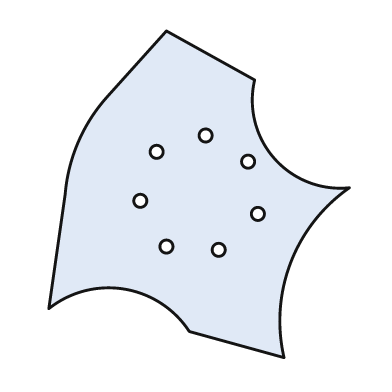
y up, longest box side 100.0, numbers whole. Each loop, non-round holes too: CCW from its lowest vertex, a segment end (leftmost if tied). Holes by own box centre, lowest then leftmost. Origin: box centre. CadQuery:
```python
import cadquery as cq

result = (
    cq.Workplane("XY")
    .moveTo(26.0, -50.0)
    .threePointArc((28.0, -21.0), (46.0, 2.0))
    .threePointArc((23.0, 11.0), (17.0, 35.0))
    .lineTo(-10.0, 50.0)
    .lineTo(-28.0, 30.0)
    .threePointArc((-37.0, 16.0), (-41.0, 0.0))
    .lineTo(-46.0, -35.0)
    .threePointArc((-23.0, -29.0), (-3.0, -42.0))
    .close()
    .moveTo(6.0, -17.0)
    .circle(2.0)
    .moveTo(-10.0, -16.0)
    .circle(2.0)
    .moveTo(18.0, -6.0)
    .circle(2.0)
    .moveTo(-18.0, -2.0)
    .circle(2.0)
    .moveTo(15.0, 10.0)
    .circle(2.0)
    .moveTo(-13.0, 13.0)
    .circle(2.0)
    .moveTo(2.0, 18.0)
    .circle(2.0)
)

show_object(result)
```